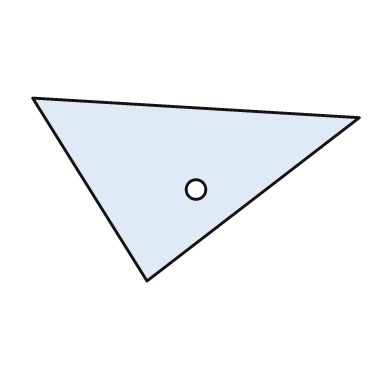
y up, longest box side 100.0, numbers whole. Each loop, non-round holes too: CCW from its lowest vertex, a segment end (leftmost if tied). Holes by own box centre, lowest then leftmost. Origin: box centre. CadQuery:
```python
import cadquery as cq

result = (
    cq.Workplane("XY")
    .moveTo(-15.0, -28.0)
    .lineTo(50.0, 22.0)
    .lineTo(-50.0, 28.0)
    .close()
    .moveTo(0.0, 0.0)
    .circle(3.0)
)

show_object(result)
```